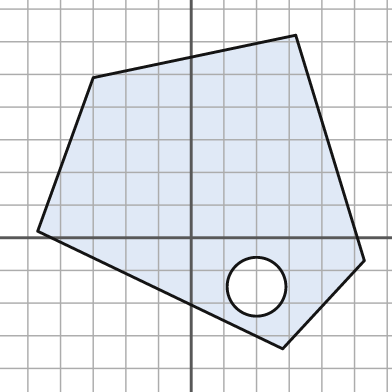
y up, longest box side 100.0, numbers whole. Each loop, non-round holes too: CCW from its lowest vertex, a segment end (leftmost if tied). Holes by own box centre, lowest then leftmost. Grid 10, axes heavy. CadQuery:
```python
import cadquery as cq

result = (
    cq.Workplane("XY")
    .moveTo(28.0, -34.0)
    .lineTo(53.0, -7.0)
    .lineTo(32.0, 62.0)
    .lineTo(-30.0, 49.0)
    .lineTo(-47.0, 2.0)
    .close()
    .moveTo(20.0, -15.0)
    .circle(9.0)
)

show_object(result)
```